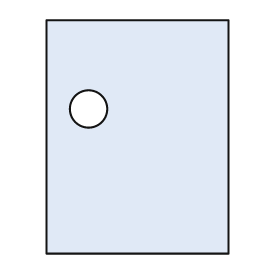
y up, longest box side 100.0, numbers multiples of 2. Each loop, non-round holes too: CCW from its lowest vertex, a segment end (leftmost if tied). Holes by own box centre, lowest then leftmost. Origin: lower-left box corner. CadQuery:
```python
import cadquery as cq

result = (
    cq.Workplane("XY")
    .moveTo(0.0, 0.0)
    .lineTo(78.0, 0.0)
    .lineTo(78.0, 100.0)
    .lineTo(0.0, 100.0)
    .close()
    .moveTo(18.0, 62.0)
    .circle(8.0)
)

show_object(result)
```